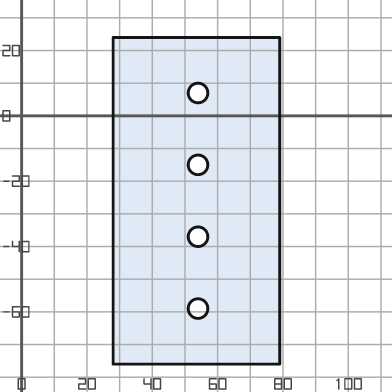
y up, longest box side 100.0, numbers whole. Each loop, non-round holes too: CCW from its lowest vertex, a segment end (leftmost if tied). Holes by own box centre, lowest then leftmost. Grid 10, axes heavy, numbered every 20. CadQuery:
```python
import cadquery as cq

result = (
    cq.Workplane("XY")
    .moveTo(28.0, -76.0)
    .lineTo(79.0, -76.0)
    .lineTo(79.0, 24.0)
    .lineTo(28.0, 24.0)
    .close()
    .moveTo(54.0, -59.0)
    .circle(3.0)
    .moveTo(54.0, -37.0)
    .circle(3.0)
    .moveTo(54.0, -15.0)
    .circle(3.0)
    .moveTo(54.0, 7.0)
    .circle(3.0)
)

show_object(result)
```